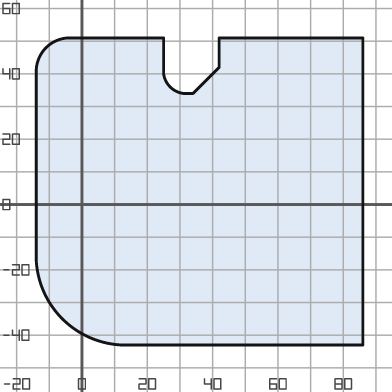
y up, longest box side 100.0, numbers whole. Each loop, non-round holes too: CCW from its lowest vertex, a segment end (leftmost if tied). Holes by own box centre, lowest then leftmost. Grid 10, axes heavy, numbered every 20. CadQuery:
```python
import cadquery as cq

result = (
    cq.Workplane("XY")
    .moveTo(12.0, -43.0)
    .lineTo(86.0, -43.0)
    .lineTo(86.0, 51.0)
    .lineTo(42.0, 51.0)
    .lineTo(42.0, 42.0)
    .lineTo(34.0, 34.0)
    .lineTo(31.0, 34.0)
    .threePointArc((27.0, 36.0), (25.0, 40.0))
    .lineTo(25.0, 51.0)
    .lineTo(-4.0, 51.0)
    .threePointArc((-11.0, 48.0), (-14.0, 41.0))
    .lineTo(-14.0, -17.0)
    .threePointArc((-6.0, -35.0), (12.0, -43.0))
    .close()
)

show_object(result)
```